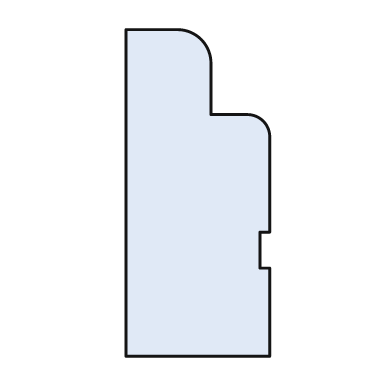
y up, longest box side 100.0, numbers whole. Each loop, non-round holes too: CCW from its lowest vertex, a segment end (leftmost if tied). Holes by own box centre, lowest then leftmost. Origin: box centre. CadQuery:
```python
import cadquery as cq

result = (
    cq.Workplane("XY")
    .moveTo(-22.0, -50.0)
    .lineTo(22.0, -50.0)
    .lineTo(22.0, -23.0)
    .lineTo(19.0, -23.0)
    .lineTo(19.0, -12.0)
    .lineTo(22.0, -12.0)
    .lineTo(22.0, 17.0)
    .threePointArc((20.0, 22.0), (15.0, 24.0))
    .lineTo(4.0, 24.0)
    .lineTo(4.0, 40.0)
    .threePointArc((1.0, 47.0), (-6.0, 50.0))
    .lineTo(-22.0, 50.0)
    .close()
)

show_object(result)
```